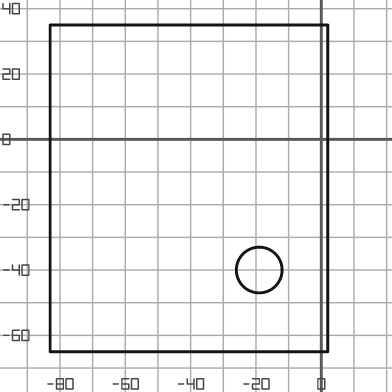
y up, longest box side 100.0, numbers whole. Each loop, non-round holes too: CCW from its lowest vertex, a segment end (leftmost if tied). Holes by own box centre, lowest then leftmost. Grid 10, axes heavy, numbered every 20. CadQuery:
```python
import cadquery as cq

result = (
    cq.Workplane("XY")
    .moveTo(-83.0, -65.0)
    .lineTo(2.0, -65.0)
    .lineTo(2.0, 35.0)
    .lineTo(-83.0, 35.0)
    .close()
    .moveTo(-19.0, -40.0)
    .circle(7.0)
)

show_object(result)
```